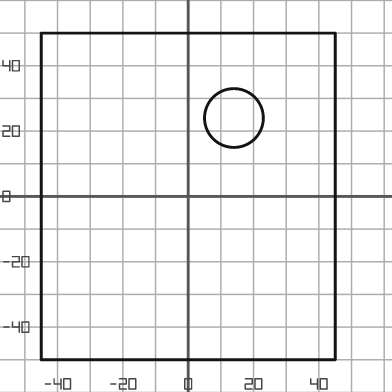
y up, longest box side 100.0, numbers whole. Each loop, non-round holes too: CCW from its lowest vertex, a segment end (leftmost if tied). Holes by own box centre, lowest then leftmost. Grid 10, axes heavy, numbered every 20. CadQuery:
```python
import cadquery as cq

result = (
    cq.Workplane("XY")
    .moveTo(-45.0, -50.0)
    .lineTo(45.0, -50.0)
    .lineTo(45.0, 50.0)
    .lineTo(-45.0, 50.0)
    .close()
    .moveTo(14.0, 24.0)
    .circle(9.0)
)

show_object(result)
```